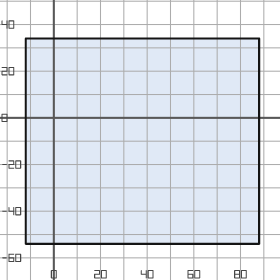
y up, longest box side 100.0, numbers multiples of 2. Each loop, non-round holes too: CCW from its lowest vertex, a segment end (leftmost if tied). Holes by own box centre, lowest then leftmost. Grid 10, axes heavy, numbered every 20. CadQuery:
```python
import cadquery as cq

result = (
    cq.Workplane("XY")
    .moveTo(-12.0, -54.0)
    .lineTo(88.0, -54.0)
    .lineTo(88.0, 34.0)
    .lineTo(-12.0, 34.0)
    .close()
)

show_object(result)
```